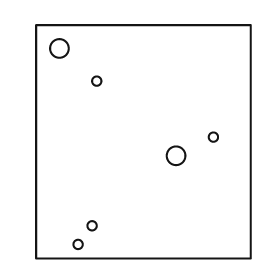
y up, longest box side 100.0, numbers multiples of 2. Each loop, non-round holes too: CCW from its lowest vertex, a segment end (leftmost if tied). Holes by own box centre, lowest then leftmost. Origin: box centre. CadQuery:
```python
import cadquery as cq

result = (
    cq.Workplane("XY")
    .moveTo(-46.0, -50.0)
    .lineTo(46.0, -50.0)
    .lineTo(46.0, 50.0)
    .lineTo(-46.0, 50.0)
    .close()
    .moveTo(-28.0, -44.0)
    .circle(2.0)
    .moveTo(-22.0, -36.0)
    .circle(2.0)
    .moveTo(14.0, -6.0)
    .circle(4.0)
    .moveTo(30.0, 2.0)
    .circle(2.0)
    .moveTo(-20.0, 26.0)
    .circle(2.0)
    .moveTo(-36.0, 40.0)
    .circle(4.0)
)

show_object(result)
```